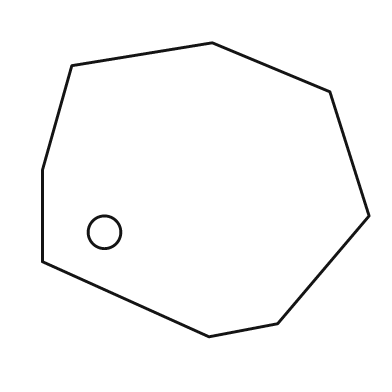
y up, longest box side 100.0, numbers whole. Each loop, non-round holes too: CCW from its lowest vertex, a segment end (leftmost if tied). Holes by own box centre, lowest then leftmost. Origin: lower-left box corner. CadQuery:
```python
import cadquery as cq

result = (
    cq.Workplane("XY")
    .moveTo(51.0, 0.0)
    .lineTo(72.0, 4.0)
    .lineTo(100.0, 37.0)
    .lineTo(88.0, 75.0)
    .lineTo(52.0, 90.0)
    .lineTo(9.0, 83.0)
    .lineTo(0.0, 51.0)
    .lineTo(0.0, 23.0)
    .close()
    .moveTo(19.0, 32.0)
    .circle(5.0)
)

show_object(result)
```